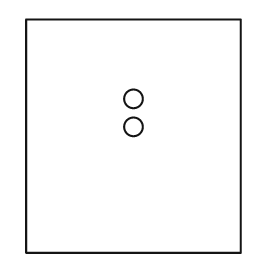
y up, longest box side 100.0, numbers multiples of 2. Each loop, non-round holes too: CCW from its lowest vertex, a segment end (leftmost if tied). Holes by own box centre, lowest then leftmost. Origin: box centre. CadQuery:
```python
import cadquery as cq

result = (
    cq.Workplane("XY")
    .moveTo(-46.0, -50.0)
    .lineTo(46.0, -50.0)
    .lineTo(46.0, 50.0)
    .lineTo(-46.0, 50.0)
    .close()
    .moveTo(0.0, 4.0)
    .circle(4.0)
    .moveTo(0.0, 16.0)
    .circle(4.0)
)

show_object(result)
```